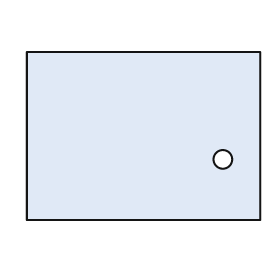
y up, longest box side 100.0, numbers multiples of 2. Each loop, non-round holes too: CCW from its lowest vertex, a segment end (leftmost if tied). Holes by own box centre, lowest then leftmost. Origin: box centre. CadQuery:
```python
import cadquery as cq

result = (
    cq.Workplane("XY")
    .moveTo(-50.0, -36.0)
    .lineTo(50.0, -36.0)
    .lineTo(50.0, 36.0)
    .lineTo(-50.0, 36.0)
    .close()
    .moveTo(34.0, -10.0)
    .circle(4.0)
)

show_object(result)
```